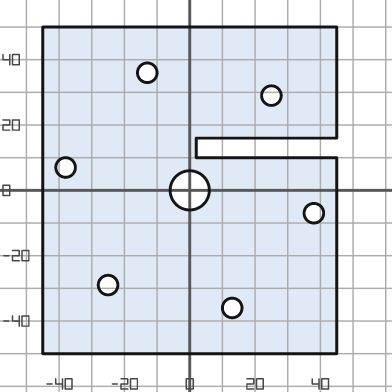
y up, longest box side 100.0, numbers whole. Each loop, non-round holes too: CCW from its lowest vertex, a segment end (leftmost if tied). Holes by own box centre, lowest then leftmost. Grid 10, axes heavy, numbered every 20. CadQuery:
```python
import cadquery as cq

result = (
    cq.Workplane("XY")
    .moveTo(-45.0, -50.0)
    .lineTo(45.0, -50.0)
    .lineTo(45.0, 10.0)
    .lineTo(2.0, 10.0)
    .lineTo(2.0, 16.0)
    .lineTo(45.0, 16.0)
    .lineTo(45.0, 50.0)
    .lineTo(-45.0, 50.0)
    .close()
    .moveTo(13.0, -36.0)
    .circle(3.0)
    .moveTo(-25.0, -29.0)
    .circle(3.0)
    .moveTo(38.0, -7.0)
    .circle(3.0)
    .moveTo(0.0, 0.0)
    .circle(6.0)
    .moveTo(-38.0, 7.0)
    .circle(3.0)
    .moveTo(25.0, 29.0)
    .circle(3.0)
    .moveTo(-13.0, 36.0)
    .circle(3.0)
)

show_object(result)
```